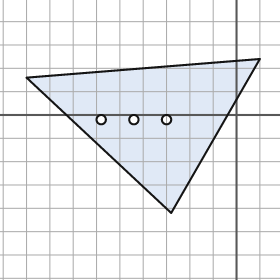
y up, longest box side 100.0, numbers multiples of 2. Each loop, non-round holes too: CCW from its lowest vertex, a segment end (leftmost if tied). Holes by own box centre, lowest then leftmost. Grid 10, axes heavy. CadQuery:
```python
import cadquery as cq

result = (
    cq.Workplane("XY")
    .moveTo(-28.0, -42.0)
    .lineTo(10.0, 24.0)
    .lineTo(-90.0, 16.0)
    .close()
    .moveTo(-58.0, -2.0)
    .circle(2.0)
    .moveTo(-44.0, -2.0)
    .circle(2.0)
    .moveTo(-30.0, -2.0)
    .circle(2.0)
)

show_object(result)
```